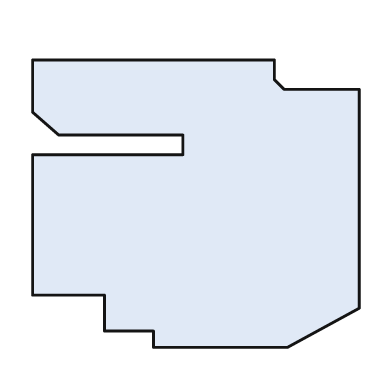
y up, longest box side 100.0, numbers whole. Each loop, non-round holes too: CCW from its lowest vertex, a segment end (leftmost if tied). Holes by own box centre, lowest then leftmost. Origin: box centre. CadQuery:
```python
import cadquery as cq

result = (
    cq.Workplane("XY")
    .moveTo(-13.0, -44.0)
    .lineTo(28.0, -44.0)
    .lineTo(50.0, -32.0)
    .lineTo(50.0, 35.0)
    .lineTo(27.0, 35.0)
    .lineTo(24.0, 38.0)
    .lineTo(24.0, 44.0)
    .lineTo(-50.0, 44.0)
    .lineTo(-50.0, 28.0)
    .lineTo(-42.0, 21.0)
    .lineTo(-4.0, 21.0)
    .lineTo(-4.0, 15.0)
    .lineTo(-50.0, 15.0)
    .lineTo(-50.0, -28.0)
    .lineTo(-28.0, -28.0)
    .lineTo(-28.0, -39.0)
    .lineTo(-13.0, -39.0)
    .close()
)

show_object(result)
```